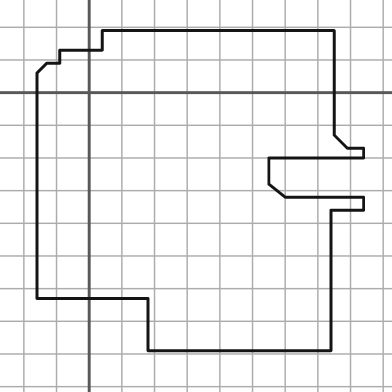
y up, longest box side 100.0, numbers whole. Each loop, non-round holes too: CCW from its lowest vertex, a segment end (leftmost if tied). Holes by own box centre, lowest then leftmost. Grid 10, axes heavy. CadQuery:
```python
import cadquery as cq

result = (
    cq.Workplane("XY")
    .moveTo(18.0, -79.0)
    .lineTo(74.0, -79.0)
    .lineTo(74.0, -36.0)
    .lineTo(84.0, -36.0)
    .lineTo(84.0, -32.0)
    .lineTo(60.0, -32.0)
    .lineTo(55.0, -28.0)
    .lineTo(55.0, -20.0)
    .lineTo(84.0, -20.0)
    .lineTo(84.0, -17.0)
    .lineTo(79.0, -17.0)
    .lineTo(75.0, -13.0)
    .lineTo(75.0, 19.0)
    .lineTo(4.0, 19.0)
    .lineTo(4.0, 13.0)
    .lineTo(-9.0, 13.0)
    .lineTo(-9.0, 9.0)
    .lineTo(-13.0, 9.0)
    .lineTo(-16.0, 6.0)
    .lineTo(-16.0, -63.0)
    .lineTo(18.0, -63.0)
    .close()
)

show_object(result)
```